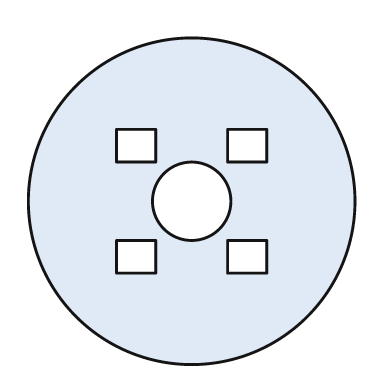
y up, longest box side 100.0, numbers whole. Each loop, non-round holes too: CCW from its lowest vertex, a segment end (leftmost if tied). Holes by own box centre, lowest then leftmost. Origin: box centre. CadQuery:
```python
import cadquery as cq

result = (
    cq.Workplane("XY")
    .moveTo(0.0, 0.0)
    .circle(50.0)
    .moveTo(-23.0, -22.0)
    .lineTo(-11.0, -22.0)
    .lineTo(-11.0, -12.0)
    .lineTo(-23.0, -12.0)
    .close()
    .moveTo(11.0, -22.0)
    .lineTo(23.0, -22.0)
    .lineTo(23.0, -12.0)
    .lineTo(11.0, -12.0)
    .close()
    .moveTo(0.0, 0.0)
    .circle(12.0)
    .moveTo(-23.0, 12.0)
    .lineTo(-11.0, 12.0)
    .lineTo(-11.0, 22.0)
    .lineTo(-23.0, 22.0)
    .close()
    .moveTo(11.0, 12.0)
    .lineTo(23.0, 12.0)
    .lineTo(23.0, 22.0)
    .lineTo(11.0, 22.0)
    .close()
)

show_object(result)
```